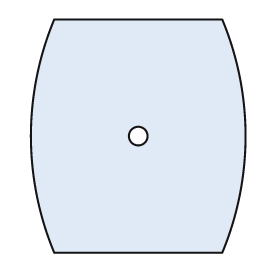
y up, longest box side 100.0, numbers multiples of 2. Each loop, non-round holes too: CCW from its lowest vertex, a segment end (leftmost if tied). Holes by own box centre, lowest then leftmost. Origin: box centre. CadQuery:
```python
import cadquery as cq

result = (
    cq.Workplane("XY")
    .moveTo(-36.0, -50.0)
    .lineTo(36.0, -50.0)
    .threePointArc((46.0, 0.0), (36.0, 50.0))
    .lineTo(-36.0, 50.0)
    .threePointArc((-46.0, 0.0), (-36.0, -50.0))
    .close()
    .moveTo(0.0, 0.0)
    .circle(4.0)
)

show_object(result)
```